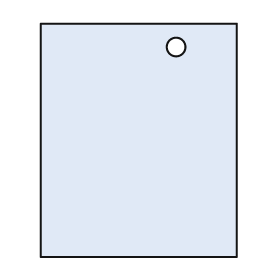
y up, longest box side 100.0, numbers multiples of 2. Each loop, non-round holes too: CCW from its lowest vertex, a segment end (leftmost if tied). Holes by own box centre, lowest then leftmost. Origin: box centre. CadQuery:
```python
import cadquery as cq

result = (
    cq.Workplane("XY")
    .moveTo(-42.0, -50.0)
    .lineTo(42.0, -50.0)
    .lineTo(42.0, 50.0)
    .lineTo(-42.0, 50.0)
    .close()
    .moveTo(16.0, 40.0)
    .circle(4.0)
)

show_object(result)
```